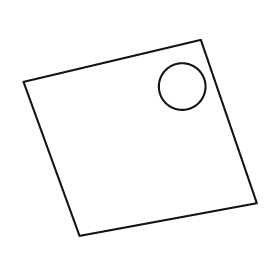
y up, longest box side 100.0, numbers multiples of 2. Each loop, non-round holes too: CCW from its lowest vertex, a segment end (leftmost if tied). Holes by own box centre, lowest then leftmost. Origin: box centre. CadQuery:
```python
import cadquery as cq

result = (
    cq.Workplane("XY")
    .moveTo(-26.0, -42.0)
    .lineTo(50.0, -28.0)
    .lineTo(26.0, 42.0)
    .lineTo(-50.0, 24.0)
    .close()
    .moveTo(18.0, 22.0)
    .circle(10.0)
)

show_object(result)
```